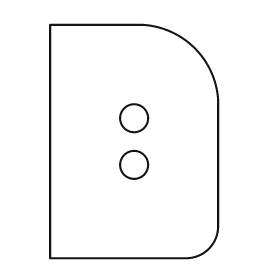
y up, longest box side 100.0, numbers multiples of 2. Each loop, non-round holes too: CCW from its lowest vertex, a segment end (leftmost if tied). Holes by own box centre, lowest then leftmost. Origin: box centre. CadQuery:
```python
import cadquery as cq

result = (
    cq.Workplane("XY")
    .moveTo(-36.0, -50.0)
    .lineTo(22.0, -50.0)
    .threePointArc((32.0, -46.0), (36.0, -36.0))
    .lineTo(36.0, 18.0)
    .threePointArc((26.0, 40.0), (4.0, 50.0))
    .lineTo(-36.0, 50.0)
    .close()
    .moveTo(0.0, -10.0)
    .circle(6.0)
    .moveTo(0.0, 10.0)
    .circle(6.0)
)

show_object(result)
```